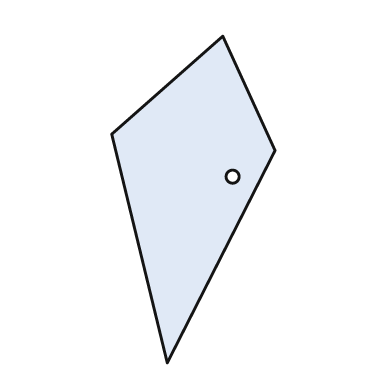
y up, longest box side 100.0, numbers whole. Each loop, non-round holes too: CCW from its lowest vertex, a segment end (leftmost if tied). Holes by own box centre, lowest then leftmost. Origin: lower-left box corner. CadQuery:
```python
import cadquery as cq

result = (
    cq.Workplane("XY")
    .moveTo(17.0, 0.0)
    .lineTo(50.0, 65.0)
    .lineTo(34.0, 100.0)
    .lineTo(0.0, 70.0)
    .close()
    .moveTo(37.0, 57.0)
    .circle(2.0)
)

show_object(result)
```